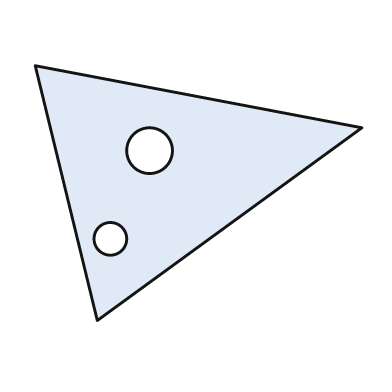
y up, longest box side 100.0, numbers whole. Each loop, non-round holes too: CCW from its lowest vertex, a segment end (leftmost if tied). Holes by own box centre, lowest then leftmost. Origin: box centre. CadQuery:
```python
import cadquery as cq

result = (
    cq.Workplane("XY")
    .moveTo(-31.0, -39.0)
    .lineTo(50.0, 20.0)
    .lineTo(-50.0, 39.0)
    .close()
    .moveTo(-27.0, -14.0)
    .circle(5.0)
    .moveTo(-15.0, 13.0)
    .circle(7.0)
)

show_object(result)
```